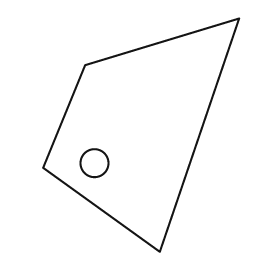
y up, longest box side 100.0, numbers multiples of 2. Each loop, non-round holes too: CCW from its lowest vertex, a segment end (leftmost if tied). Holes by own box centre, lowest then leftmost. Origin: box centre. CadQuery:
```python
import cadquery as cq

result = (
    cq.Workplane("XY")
    .moveTo(8.0, -50.0)
    .lineTo(42.0, 50.0)
    .lineTo(-24.0, 30.0)
    .lineTo(-42.0, -14.0)
    .close()
    .moveTo(-20.0, -12.0)
    .circle(6.0)
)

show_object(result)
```